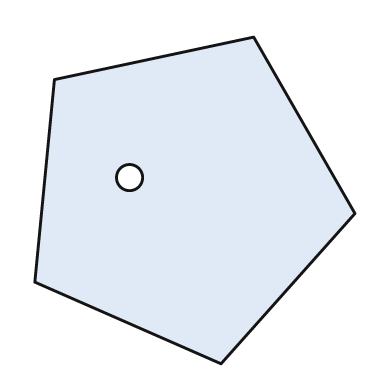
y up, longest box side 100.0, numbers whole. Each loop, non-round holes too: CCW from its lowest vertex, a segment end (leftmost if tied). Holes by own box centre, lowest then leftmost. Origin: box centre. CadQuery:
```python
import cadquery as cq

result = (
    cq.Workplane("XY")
    .moveTo(8.0, -50.0)
    .lineTo(49.0, -4.0)
    .lineTo(18.0, 50.0)
    .lineTo(-43.0, 37.0)
    .lineTo(-49.0, -25.0)
    .close()
    .moveTo(-20.0, 7.0)
    .circle(4.0)
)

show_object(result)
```